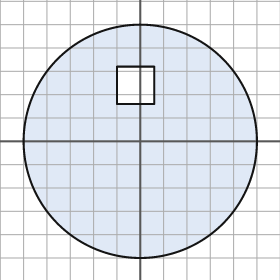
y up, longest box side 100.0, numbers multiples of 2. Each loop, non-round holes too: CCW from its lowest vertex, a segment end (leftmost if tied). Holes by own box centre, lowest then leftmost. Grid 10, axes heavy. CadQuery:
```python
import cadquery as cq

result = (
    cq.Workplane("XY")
    .moveTo(0.0, 0.0)
    .circle(50.0)
    .moveTo(-10.0, 16.0)
    .lineTo(6.0, 16.0)
    .lineTo(6.0, 32.0)
    .lineTo(-10.0, 32.0)
    .close()
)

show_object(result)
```